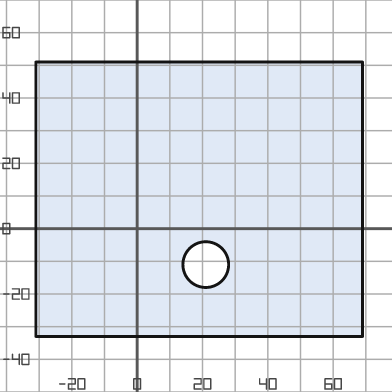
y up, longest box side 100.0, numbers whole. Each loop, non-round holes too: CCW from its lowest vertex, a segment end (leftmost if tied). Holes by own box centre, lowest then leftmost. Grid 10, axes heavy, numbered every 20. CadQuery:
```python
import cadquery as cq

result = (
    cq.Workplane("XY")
    .moveTo(-31.0, -33.0)
    .lineTo(69.0, -33.0)
    .lineTo(69.0, 51.0)
    .lineTo(-31.0, 51.0)
    .close()
    .moveTo(21.0, -11.0)
    .circle(7.0)
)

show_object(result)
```